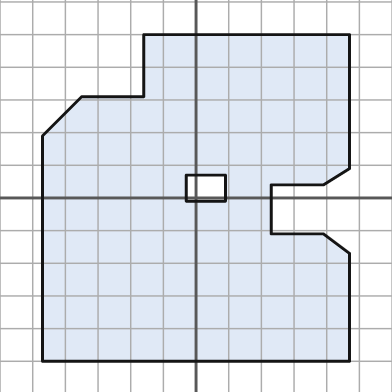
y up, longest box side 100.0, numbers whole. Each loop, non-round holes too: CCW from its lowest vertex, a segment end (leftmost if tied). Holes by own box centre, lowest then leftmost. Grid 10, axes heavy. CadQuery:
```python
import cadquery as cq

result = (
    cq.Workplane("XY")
    .moveTo(-47.0, -50.0)
    .lineTo(47.0, -50.0)
    .lineTo(47.0, -17.0)
    .lineTo(39.0, -11.0)
    .lineTo(23.0, -11.0)
    .lineTo(23.0, 4.0)
    .lineTo(39.0, 4.0)
    .lineTo(47.0, 9.0)
    .lineTo(47.0, 50.0)
    .lineTo(-16.0, 50.0)
    .lineTo(-16.0, 31.0)
    .lineTo(-35.0, 31.0)
    .lineTo(-47.0, 19.0)
    .close()
    .moveTo(-3.0, -1.0)
    .lineTo(9.0, -1.0)
    .lineTo(9.0, 7.0)
    .lineTo(-3.0, 7.0)
    .close()
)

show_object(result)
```